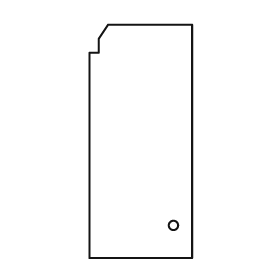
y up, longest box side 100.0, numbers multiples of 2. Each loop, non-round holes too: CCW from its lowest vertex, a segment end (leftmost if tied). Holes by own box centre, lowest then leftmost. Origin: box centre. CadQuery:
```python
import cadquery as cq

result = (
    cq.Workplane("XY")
    .moveTo(-22.0, -50.0)
    .lineTo(22.0, -50.0)
    .lineTo(22.0, 50.0)
    .lineTo(-14.0, 50.0)
    .lineTo(-18.0, 44.0)
    .lineTo(-18.0, 38.0)
    .lineTo(-22.0, 38.0)
    .close()
    .moveTo(14.0, -36.0)
    .circle(2.0)
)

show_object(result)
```